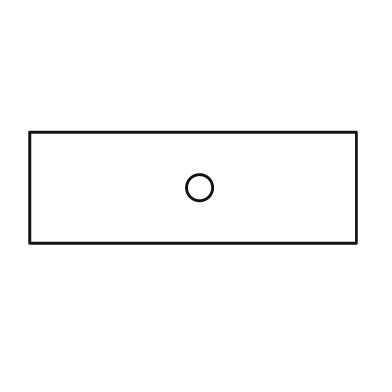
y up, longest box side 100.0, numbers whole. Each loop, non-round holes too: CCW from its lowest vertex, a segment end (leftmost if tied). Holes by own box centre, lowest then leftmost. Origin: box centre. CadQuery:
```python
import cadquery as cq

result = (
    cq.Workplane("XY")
    .moveTo(-50.0, -17.0)
    .lineTo(50.0, -17.0)
    .lineTo(50.0, 17.0)
    .lineTo(-50.0, 17.0)
    .close()
    .moveTo(2.0, 0.0)
    .circle(4.0)
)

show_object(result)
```